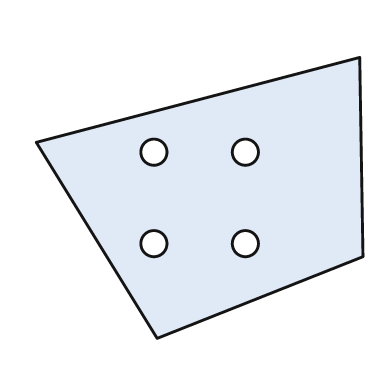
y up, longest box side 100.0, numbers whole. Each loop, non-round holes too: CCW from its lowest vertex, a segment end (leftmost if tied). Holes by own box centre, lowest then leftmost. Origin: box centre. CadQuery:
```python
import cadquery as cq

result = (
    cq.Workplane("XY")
    .moveTo(-13.0, -43.0)
    .lineTo(50.0, -18.0)
    .lineTo(49.0, 43.0)
    .lineTo(-50.0, 17.0)
    .close()
    .moveTo(-14.0, -14.0)
    .circle(4.0)
    .moveTo(14.0, -14.0)
    .circle(4.0)
    .moveTo(-14.0, 14.0)
    .circle(4.0)
    .moveTo(14.0, 14.0)
    .circle(4.0)
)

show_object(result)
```